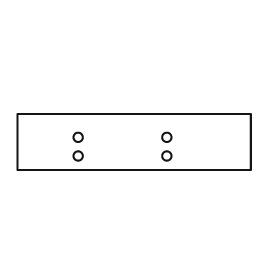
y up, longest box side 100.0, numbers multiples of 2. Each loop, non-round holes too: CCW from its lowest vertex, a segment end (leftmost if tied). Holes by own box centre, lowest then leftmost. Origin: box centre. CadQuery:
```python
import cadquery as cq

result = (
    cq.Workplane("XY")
    .moveTo(-50.0, -12.0)
    .lineTo(50.0, -12.0)
    .lineTo(50.0, 12.0)
    .lineTo(-50.0, 12.0)
    .close()
    .moveTo(-24.0, -6.0)
    .circle(2.0)
    .moveTo(14.0, -6.0)
    .circle(2.0)
    .moveTo(-24.0, 2.0)
    .circle(2.0)
    .moveTo(14.0, 2.0)
    .circle(2.0)
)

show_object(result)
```